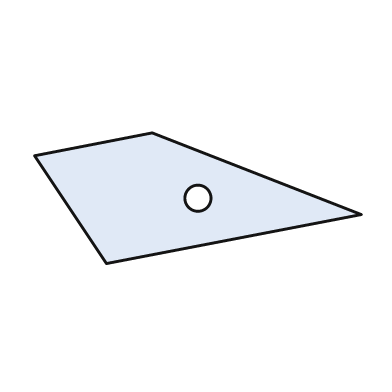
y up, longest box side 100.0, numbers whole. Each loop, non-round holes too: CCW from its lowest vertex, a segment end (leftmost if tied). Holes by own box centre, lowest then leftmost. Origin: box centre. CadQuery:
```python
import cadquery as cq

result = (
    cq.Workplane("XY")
    .moveTo(-28.0, -20.0)
    .lineTo(50.0, -5.0)
    .lineTo(-14.0, 20.0)
    .lineTo(-50.0, 13.0)
    .close()
    .moveTo(0.0, 0.0)
    .circle(4.0)
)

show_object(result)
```